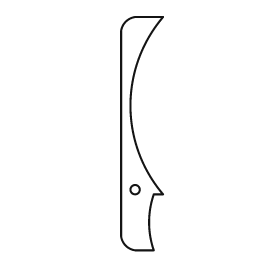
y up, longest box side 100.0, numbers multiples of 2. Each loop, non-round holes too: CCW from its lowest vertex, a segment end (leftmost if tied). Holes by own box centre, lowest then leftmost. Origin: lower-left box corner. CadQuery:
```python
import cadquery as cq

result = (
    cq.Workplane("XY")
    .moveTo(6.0, 0.0)
    .lineTo(14.0, 0.0)
    .threePointArc((12.0, 12.0), (14.0, 24.0))
    .lineTo(18.0, 24.0)
    .threePointArc((4.0, 62.0), (18.0, 100.0))
    .lineTo(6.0, 100.0)
    .threePointArc((2.0, 98.0), (0.0, 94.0))
    .lineTo(0.0, 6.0)
    .threePointArc((2.0, 2.0), (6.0, 0.0))
    .close()
    .moveTo(6.0, 26.0)
    .circle(2.0)
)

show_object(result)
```